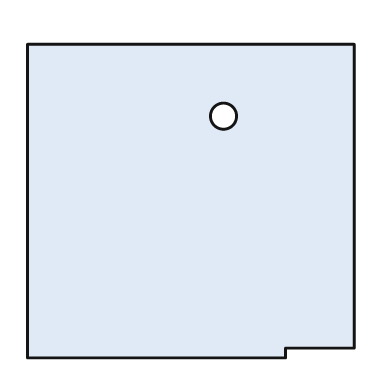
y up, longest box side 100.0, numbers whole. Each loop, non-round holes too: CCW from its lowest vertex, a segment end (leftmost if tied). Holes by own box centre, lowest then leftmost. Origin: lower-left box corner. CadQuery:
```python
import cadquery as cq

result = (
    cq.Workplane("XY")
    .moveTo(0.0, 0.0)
    .lineTo(79.0, 0.0)
    .lineTo(79.0, 3.0)
    .lineTo(100.0, 3.0)
    .lineTo(100.0, 96.0)
    .lineTo(0.0, 96.0)
    .close()
    .moveTo(60.0, 74.0)
    .circle(4.0)
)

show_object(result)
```